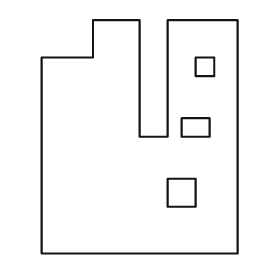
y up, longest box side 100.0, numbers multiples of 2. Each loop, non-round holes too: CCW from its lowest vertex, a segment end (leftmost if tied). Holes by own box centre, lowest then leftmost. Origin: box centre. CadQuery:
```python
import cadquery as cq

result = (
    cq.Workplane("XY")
    .moveTo(-42.0, -50.0)
    .lineTo(42.0, -50.0)
    .lineTo(42.0, 50.0)
    .lineTo(12.0, 50.0)
    .lineTo(12.0, 0.0)
    .lineTo(0.0, 0.0)
    .lineTo(0.0, 50.0)
    .lineTo(-20.0, 50.0)
    .lineTo(-20.0, 34.0)
    .lineTo(-42.0, 34.0)
    .close()
    .moveTo(12.0, -30.0)
    .lineTo(24.0, -30.0)
    .lineTo(24.0, -18.0)
    .lineTo(12.0, -18.0)
    .close()
    .moveTo(18.0, 0.0)
    .lineTo(30.0, 0.0)
    .lineTo(30.0, 8.0)
    .lineTo(18.0, 8.0)
    .close()
    .moveTo(24.0, 26.0)
    .lineTo(32.0, 26.0)
    .lineTo(32.0, 34.0)
    .lineTo(24.0, 34.0)
    .close()
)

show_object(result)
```